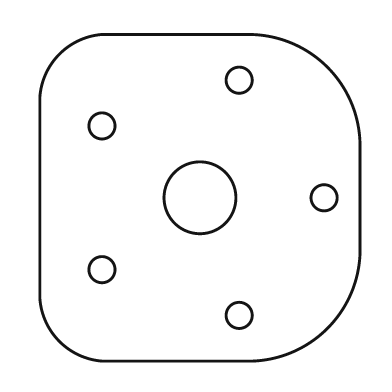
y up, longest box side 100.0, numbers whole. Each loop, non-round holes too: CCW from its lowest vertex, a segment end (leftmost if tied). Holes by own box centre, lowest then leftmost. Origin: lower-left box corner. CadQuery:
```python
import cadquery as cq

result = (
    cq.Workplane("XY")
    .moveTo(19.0, 0.0)
    .lineTo(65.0, 0.0)
    .threePointArc((88.0, 10.0), (98.0, 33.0))
    .lineTo(98.0, 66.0)
    .threePointArc((88.0, 90.0), (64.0, 100.0))
    .lineTo(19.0, 100.0)
    .threePointArc((6.0, 94.0), (0.0, 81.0))
    .lineTo(0.0, 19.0)
    .threePointArc((6.0, 6.0), (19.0, 0.0))
    .close()
    .moveTo(61.0, 14.0)
    .circle(4.0)
    .moveTo(19.0, 28.0)
    .circle(4.0)
    .moveTo(49.0, 50.0)
    .circle(11.0)
    .moveTo(87.0, 50.0)
    .circle(4.0)
    .moveTo(19.0, 72.0)
    .circle(4.0)
    .moveTo(61.0, 86.0)
    .circle(4.0)
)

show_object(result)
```